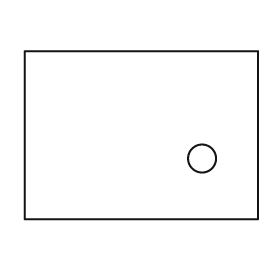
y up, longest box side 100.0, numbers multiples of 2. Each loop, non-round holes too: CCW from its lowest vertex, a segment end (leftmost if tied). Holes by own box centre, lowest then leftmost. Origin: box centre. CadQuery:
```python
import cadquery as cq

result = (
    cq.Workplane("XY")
    .moveTo(-50.0, -36.0)
    .lineTo(50.0, -36.0)
    .lineTo(50.0, 36.0)
    .lineTo(-50.0, 36.0)
    .close()
    .moveTo(26.0, -10.0)
    .circle(6.0)
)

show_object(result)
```